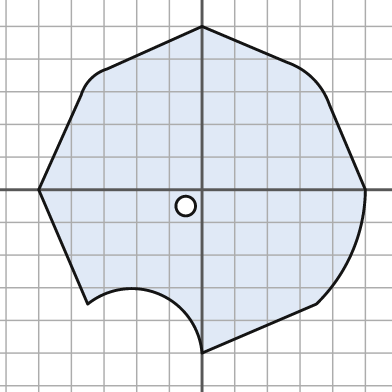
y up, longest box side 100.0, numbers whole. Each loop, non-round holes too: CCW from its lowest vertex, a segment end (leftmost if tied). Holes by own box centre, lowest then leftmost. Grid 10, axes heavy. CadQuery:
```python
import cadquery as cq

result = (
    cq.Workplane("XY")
    .moveTo(0.0, -50.0)
    .lineTo(35.0, -35.0)
    .threePointArc((46.0, -19.0), (50.0, 0.0))
    .lineTo(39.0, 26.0)
    .threePointArc((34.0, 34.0), (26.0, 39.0))
    .lineTo(0.0, 50.0)
    .lineTo(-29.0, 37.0)
    .threePointArc((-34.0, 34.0), (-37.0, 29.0))
    .lineTo(-50.0, 0.0)
    .lineTo(-35.0, -35.0)
    .threePointArc((-13.0, -32.0), (0.0, -50.0))
    .close()
    .moveTo(-5.0, -5.0)
    .circle(3.0)
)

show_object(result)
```